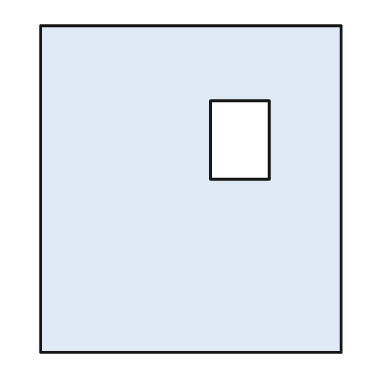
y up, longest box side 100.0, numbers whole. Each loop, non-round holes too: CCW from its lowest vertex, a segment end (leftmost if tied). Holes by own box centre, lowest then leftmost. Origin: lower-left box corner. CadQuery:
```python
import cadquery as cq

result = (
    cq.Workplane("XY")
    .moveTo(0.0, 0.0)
    .lineTo(92.0, 0.0)
    .lineTo(92.0, 100.0)
    .lineTo(0.0, 100.0)
    .close()
    .moveTo(52.0, 53.0)
    .lineTo(70.0, 53.0)
    .lineTo(70.0, 77.0)
    .lineTo(52.0, 77.0)
    .close()
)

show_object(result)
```